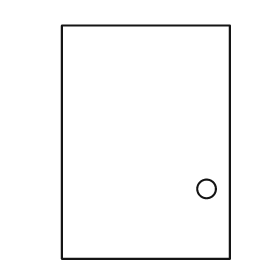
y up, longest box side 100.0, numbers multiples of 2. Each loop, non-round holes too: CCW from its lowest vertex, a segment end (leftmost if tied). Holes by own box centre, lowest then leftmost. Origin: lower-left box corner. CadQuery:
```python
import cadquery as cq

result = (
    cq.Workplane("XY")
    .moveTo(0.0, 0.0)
    .lineTo(72.0, 0.0)
    .lineTo(72.0, 100.0)
    .lineTo(0.0, 100.0)
    .close()
    .moveTo(62.0, 30.0)
    .circle(4.0)
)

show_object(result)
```